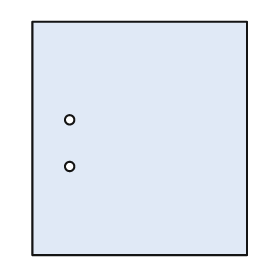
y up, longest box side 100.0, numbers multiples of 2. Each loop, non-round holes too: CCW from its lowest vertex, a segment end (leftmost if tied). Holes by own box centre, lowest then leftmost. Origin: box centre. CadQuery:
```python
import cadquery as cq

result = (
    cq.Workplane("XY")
    .moveTo(-46.0, -50.0)
    .lineTo(46.0, -50.0)
    .lineTo(46.0, 50.0)
    .lineTo(-46.0, 50.0)
    .close()
    .moveTo(-30.0, -12.0)
    .circle(2.0)
    .moveTo(-30.0, 8.0)
    .circle(2.0)
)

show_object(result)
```